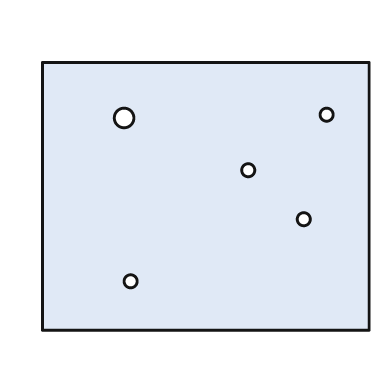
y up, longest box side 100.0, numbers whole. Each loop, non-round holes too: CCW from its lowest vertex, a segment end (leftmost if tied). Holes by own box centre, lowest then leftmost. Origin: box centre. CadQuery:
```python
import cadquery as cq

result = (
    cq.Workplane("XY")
    .moveTo(-50.0, -41.0)
    .lineTo(50.0, -41.0)
    .lineTo(50.0, 41.0)
    .lineTo(-50.0, 41.0)
    .close()
    .moveTo(-23.0, -26.0)
    .circle(2.0)
    .moveTo(30.0, -7.0)
    .circle(2.0)
    .moveTo(13.0, 8.0)
    .circle(2.0)
    .moveTo(-25.0, 24.0)
    .circle(3.0)
    .moveTo(37.0, 25.0)
    .circle(2.0)
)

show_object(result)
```